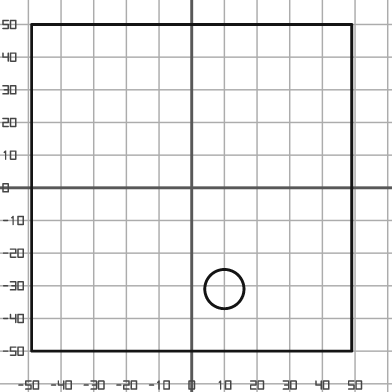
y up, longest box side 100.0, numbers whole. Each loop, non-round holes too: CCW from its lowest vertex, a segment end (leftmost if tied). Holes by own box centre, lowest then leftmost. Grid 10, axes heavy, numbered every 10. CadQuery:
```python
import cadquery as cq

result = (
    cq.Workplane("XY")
    .moveTo(-49.0, -50.0)
    .lineTo(49.0, -50.0)
    .lineTo(49.0, 50.0)
    .lineTo(-49.0, 50.0)
    .close()
    .moveTo(10.0, -31.0)
    .circle(6.0)
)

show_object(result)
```